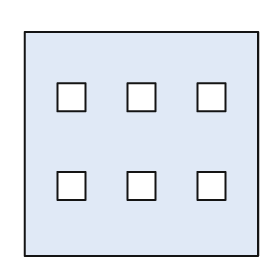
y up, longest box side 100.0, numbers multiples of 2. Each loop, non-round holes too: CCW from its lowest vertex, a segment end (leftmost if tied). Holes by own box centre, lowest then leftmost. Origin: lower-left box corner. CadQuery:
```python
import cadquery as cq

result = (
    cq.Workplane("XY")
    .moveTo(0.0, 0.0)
    .lineTo(100.0, 0.0)
    .lineTo(100.0, 96.0)
    .lineTo(0.0, 96.0)
    .close()
    .moveTo(14.0, 24.0)
    .lineTo(26.0, 24.0)
    .lineTo(26.0, 36.0)
    .lineTo(14.0, 36.0)
    .close()
    .moveTo(44.0, 24.0)
    .lineTo(56.0, 24.0)
    .lineTo(56.0, 36.0)
    .lineTo(44.0, 36.0)
    .close()
    .moveTo(74.0, 24.0)
    .lineTo(86.0, 24.0)
    .lineTo(86.0, 36.0)
    .lineTo(74.0, 36.0)
    .close()
    .moveTo(14.0, 62.0)
    .lineTo(26.0, 62.0)
    .lineTo(26.0, 74.0)
    .lineTo(14.0, 74.0)
    .close()
    .moveTo(44.0, 62.0)
    .lineTo(56.0, 62.0)
    .lineTo(56.0, 74.0)
    .lineTo(44.0, 74.0)
    .close()
    .moveTo(74.0, 62.0)
    .lineTo(86.0, 62.0)
    .lineTo(86.0, 74.0)
    .lineTo(74.0, 74.0)
    .close()
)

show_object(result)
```